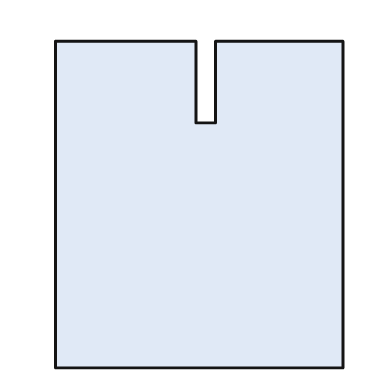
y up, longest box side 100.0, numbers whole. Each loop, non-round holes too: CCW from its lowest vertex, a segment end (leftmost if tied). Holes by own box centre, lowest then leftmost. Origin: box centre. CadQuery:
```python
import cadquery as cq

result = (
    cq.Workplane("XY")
    .moveTo(-44.0, -50.0)
    .lineTo(44.0, -50.0)
    .lineTo(44.0, 50.0)
    .lineTo(5.0, 50.0)
    .lineTo(5.0, 25.0)
    .lineTo(-1.0, 25.0)
    .lineTo(-1.0, 50.0)
    .lineTo(-44.0, 50.0)
    .close()
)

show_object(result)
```